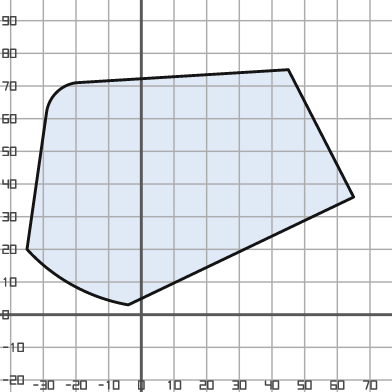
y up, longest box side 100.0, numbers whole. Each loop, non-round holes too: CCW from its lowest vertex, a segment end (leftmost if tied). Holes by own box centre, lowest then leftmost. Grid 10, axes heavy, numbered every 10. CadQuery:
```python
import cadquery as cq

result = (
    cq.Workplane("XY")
    .moveTo(-4.0, 3.0)
    .lineTo(65.0, 36.0)
    .lineTo(45.0, 75.0)
    .lineTo(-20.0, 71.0)
    .threePointArc((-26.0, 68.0), (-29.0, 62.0))
    .lineTo(-35.0, 20.0)
    .threePointArc((-21.0, 9.0), (-4.0, 3.0))
    .close()
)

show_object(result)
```